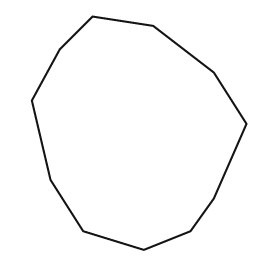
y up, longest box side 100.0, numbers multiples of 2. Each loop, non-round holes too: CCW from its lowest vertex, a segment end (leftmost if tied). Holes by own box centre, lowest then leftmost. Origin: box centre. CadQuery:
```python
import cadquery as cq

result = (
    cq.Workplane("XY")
    .moveTo(2.0, -50.0)
    .lineTo(22.0, -42.0)
    .lineTo(32.0, -28.0)
    .lineTo(46.0, 4.0)
    .lineTo(32.0, 26.0)
    .lineTo(6.0, 46.0)
    .lineTo(-20.0, 50.0)
    .lineTo(-34.0, 36.0)
    .lineTo(-46.0, 14.0)
    .lineTo(-38.0, -20.0)
    .lineTo(-24.0, -42.0)
    .close()
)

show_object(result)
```